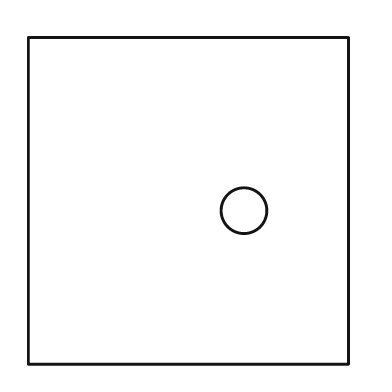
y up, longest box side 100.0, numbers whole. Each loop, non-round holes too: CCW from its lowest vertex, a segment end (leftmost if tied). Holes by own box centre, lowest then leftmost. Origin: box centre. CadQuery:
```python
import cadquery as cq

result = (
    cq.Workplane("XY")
    .moveTo(-49.0, -50.0)
    .lineTo(49.0, -50.0)
    .lineTo(49.0, 50.0)
    .lineTo(-49.0, 50.0)
    .close()
    .moveTo(17.0, -3.0)
    .circle(7.0)
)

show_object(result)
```